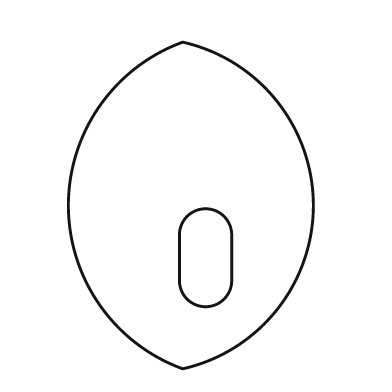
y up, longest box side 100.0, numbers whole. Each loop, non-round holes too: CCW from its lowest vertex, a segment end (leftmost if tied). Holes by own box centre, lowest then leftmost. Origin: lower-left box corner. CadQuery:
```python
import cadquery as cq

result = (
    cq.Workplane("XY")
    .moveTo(35.0, 0.0)
    .threePointArc((75.0, 50.0), (35.0, 100.0))
    .threePointArc((0.0, 50.0), (35.0, 0.0))
    .close()
    .moveTo(34.0, 27.0)
    .threePointArc((42.0, 19.0), (50.0, 27.0))
    .lineTo(50.0, 41.0)
    .threePointArc((42.0, 49.0), (34.0, 41.0))
    .close()
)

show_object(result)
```